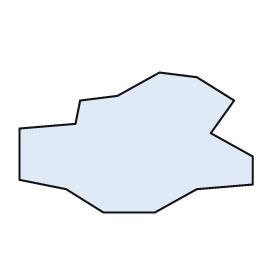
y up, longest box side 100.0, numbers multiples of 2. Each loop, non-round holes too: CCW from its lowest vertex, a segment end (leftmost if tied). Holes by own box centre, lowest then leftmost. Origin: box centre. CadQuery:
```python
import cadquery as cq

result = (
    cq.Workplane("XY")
    .moveTo(-14.0, -30.0)
    .lineTo(8.0, -30.0)
    .lineTo(26.0, -20.0)
    .lineTo(50.0, -18.0)
    .lineTo(50.0, -6.0)
    .lineTo(32.0, 4.0)
    .lineTo(42.0, 18.0)
    .lineTo(26.0, 28.0)
    .lineTo(10.0, 30.0)
    .lineTo(-8.0, 20.0)
    .lineTo(-24.0, 18.0)
    .lineTo(-26.0, 8.0)
    .lineTo(-50.0, 6.0)
    .lineTo(-50.0, -16.0)
    .lineTo(-30.0, -20.0)
    .close()
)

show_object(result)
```